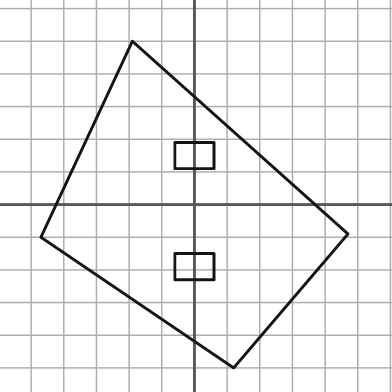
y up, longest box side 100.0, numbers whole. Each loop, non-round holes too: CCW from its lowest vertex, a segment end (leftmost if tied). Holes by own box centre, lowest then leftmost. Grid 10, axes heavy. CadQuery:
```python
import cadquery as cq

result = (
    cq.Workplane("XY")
    .moveTo(12.0, -50.0)
    .lineTo(47.0, -9.0)
    .lineTo(-19.0, 50.0)
    .lineTo(-47.0, -10.0)
    .close()
    .moveTo(-6.0, -23.0)
    .lineTo(6.0, -23.0)
    .lineTo(6.0, -15.0)
    .lineTo(-6.0, -15.0)
    .close()
    .moveTo(-6.0, 11.0)
    .lineTo(6.0, 11.0)
    .lineTo(6.0, 19.0)
    .lineTo(-6.0, 19.0)
    .close()
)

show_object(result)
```